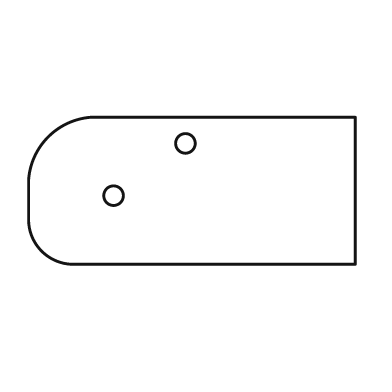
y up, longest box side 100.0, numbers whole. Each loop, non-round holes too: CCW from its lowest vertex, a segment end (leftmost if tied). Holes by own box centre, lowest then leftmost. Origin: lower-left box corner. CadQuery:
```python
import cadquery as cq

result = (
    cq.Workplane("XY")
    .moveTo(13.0, 0.0)
    .lineTo(100.0, 0.0)
    .lineTo(100.0, 45.0)
    .lineTo(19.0, 45.0)
    .threePointArc((6.0, 39.0), (0.0, 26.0))
    .lineTo(0.0, 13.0)
    .threePointArc((4.0, 4.0), (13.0, 0.0))
    .close()
    .moveTo(26.0, 21.0)
    .circle(3.0)
    .moveTo(48.0, 37.0)
    .circle(3.0)
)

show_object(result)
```